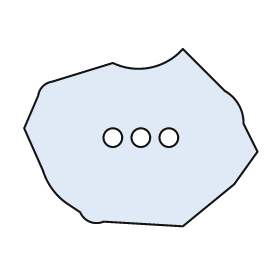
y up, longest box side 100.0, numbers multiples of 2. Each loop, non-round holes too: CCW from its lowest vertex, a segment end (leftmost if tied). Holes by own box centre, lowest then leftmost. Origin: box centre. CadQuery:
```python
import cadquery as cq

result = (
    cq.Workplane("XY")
    .moveTo(18.0, -38.0)
    .lineTo(40.0, -20.0)
    .lineTo(50.0, -6.0)
    .lineTo(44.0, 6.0)
    .threePointArc((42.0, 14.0), (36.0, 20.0))
    .lineTo(18.0, 38.0)
    .threePointArc((4.0, 30.0), (-12.0, 32.0))
    .lineTo(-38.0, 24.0)
    .threePointArc((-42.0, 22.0), (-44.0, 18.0))
    .lineTo(-50.0, 4.0)
    .lineTo(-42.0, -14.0)
    .threePointArc((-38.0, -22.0), (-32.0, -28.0))
    .lineTo(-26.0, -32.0)
    .threePointArc((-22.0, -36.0), (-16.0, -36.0))
    .close()
    .moveTo(-12.0, 0.0)
    .circle(4.0)
    .moveTo(0.0, 0.0)
    .circle(4.0)
    .moveTo(12.0, 0.0)
    .circle(4.0)
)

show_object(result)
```